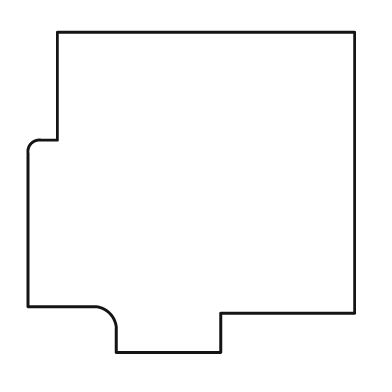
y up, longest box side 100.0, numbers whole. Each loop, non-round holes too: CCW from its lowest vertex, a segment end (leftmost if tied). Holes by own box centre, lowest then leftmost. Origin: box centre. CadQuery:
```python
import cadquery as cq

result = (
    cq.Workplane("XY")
    .moveTo(-23.0, -49.0)
    .lineTo(9.0, -49.0)
    .lineTo(9.0, -37.0)
    .lineTo(50.0, -37.0)
    .lineTo(50.0, 49.0)
    .lineTo(-41.0, 49.0)
    .lineTo(-41.0, 16.0)
    .lineTo(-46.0, 16.0)
    .threePointArc((-49.0, 15.0), (-50.0, 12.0))
    .lineTo(-50.0, -35.0)
    .lineTo(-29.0, -35.0)
    .threePointArc((-25.0, -37.0), (-23.0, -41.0))
    .close()
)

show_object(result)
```